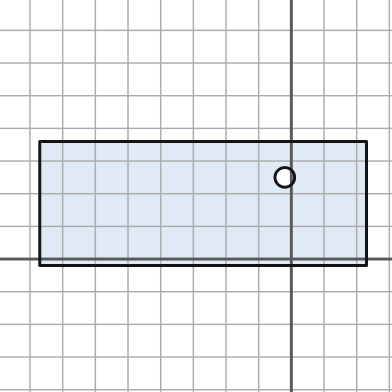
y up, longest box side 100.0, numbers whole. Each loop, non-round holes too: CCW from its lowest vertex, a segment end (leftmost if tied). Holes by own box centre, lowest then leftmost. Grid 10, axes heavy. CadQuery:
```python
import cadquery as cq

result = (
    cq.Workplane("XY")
    .moveTo(-77.0, -2.0)
    .lineTo(23.0, -2.0)
    .lineTo(23.0, 36.0)
    .lineTo(-77.0, 36.0)
    .close()
    .moveTo(-2.0, 25.0)
    .circle(3.0)
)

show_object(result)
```